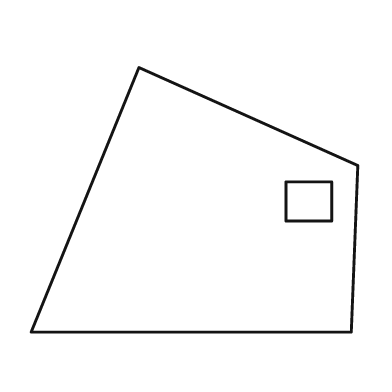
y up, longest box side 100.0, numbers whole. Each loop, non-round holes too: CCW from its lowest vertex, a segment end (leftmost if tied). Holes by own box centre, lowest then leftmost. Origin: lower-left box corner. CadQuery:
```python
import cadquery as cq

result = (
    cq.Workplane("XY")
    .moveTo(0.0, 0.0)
    .lineTo(98.0, 0.0)
    .lineTo(100.0, 51.0)
    .lineTo(33.0, 81.0)
    .close()
    .moveTo(78.0, 34.0)
    .lineTo(92.0, 34.0)
    .lineTo(92.0, 46.0)
    .lineTo(78.0, 46.0)
    .close()
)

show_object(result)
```